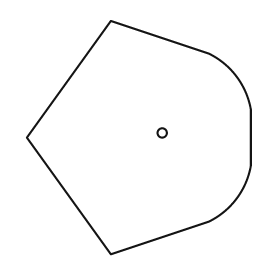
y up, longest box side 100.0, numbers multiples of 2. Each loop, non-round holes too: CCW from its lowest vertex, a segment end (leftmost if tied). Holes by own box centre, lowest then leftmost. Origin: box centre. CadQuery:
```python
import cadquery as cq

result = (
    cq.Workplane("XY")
    .moveTo(-12.0, -50.0)
    .lineTo(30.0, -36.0)
    .threePointArc((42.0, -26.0), (48.0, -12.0))
    .lineTo(48.0, 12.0)
    .threePointArc((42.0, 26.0), (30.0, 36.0))
    .lineTo(-12.0, 50.0)
    .lineTo(-48.0, 0.0)
    .close()
    .moveTo(10.0, 2.0)
    .circle(2.0)
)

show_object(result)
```